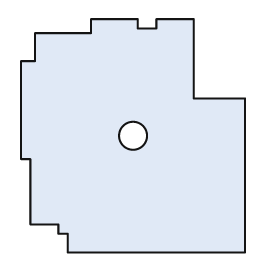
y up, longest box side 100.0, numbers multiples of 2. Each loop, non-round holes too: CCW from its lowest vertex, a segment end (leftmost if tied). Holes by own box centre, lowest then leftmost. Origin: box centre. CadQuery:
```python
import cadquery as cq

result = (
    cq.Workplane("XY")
    .moveTo(-28.0, -50.0)
    .lineTo(48.0, -50.0)
    .lineTo(48.0, 16.0)
    .lineTo(26.0, 16.0)
    .lineTo(26.0, 50.0)
    .lineTo(10.0, 50.0)
    .lineTo(10.0, 46.0)
    .lineTo(2.0, 46.0)
    .lineTo(2.0, 50.0)
    .lineTo(-18.0, 50.0)
    .lineTo(-18.0, 44.0)
    .lineTo(-42.0, 44.0)
    .lineTo(-42.0, 32.0)
    .lineTo(-48.0, 32.0)
    .lineTo(-48.0, -10.0)
    .lineTo(-44.0, -10.0)
    .lineTo(-44.0, -38.0)
    .lineTo(-32.0, -38.0)
    .lineTo(-32.0, -42.0)
    .lineTo(-28.0, -42.0)
    .close()
    .moveTo(0.0, 0.0)
    .circle(6.0)
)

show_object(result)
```